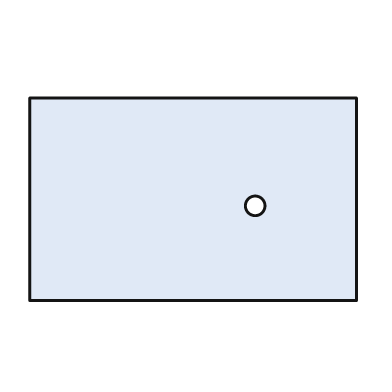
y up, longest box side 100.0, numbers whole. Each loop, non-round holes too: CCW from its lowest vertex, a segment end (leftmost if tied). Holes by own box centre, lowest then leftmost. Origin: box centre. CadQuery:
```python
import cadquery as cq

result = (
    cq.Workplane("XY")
    .moveTo(-50.0, -31.0)
    .lineTo(50.0, -31.0)
    .lineTo(50.0, 31.0)
    .lineTo(-50.0, 31.0)
    .close()
    .moveTo(19.0, -2.0)
    .circle(3.0)
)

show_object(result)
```